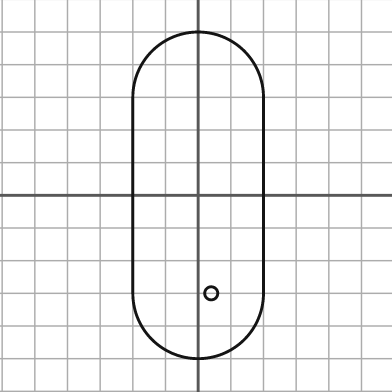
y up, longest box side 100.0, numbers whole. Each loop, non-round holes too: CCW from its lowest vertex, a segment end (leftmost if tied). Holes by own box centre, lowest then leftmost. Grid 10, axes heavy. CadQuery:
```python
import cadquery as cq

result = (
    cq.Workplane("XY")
    .moveTo(-20.0, -30.0)
    .threePointArc((0.0, -50.0), (20.0, -30.0))
    .lineTo(20.0, 30.0)
    .threePointArc((0.0, 50.0), (-20.0, 30.0))
    .close()
    .moveTo(4.0, -30.0)
    .circle(2.0)
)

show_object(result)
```